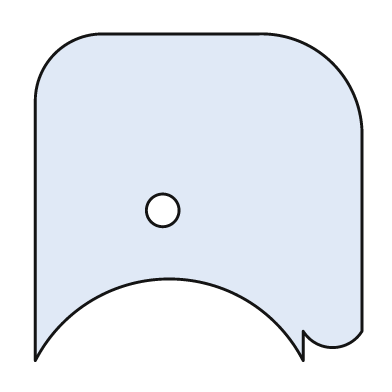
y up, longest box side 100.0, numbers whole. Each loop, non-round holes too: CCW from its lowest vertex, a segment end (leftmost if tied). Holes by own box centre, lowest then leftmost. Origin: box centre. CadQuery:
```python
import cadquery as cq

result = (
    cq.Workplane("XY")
    .moveTo(-50.0, -50.0)
    .threePointArc((-9.0, -25.0), (32.0, -50.0))
    .lineTo(32.0, -41.0)
    .threePointArc((41.0, -46.0), (50.0, -41.0))
    .lineTo(50.0, 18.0)
    .threePointArc((41.0, 41.0), (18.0, 50.0))
    .lineTo(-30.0, 50.0)
    .threePointArc((-44.0, 44.0), (-50.0, 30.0))
    .close()
    .moveTo(-11.0, -4.0)
    .circle(5.0)
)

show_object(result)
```